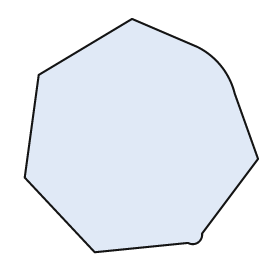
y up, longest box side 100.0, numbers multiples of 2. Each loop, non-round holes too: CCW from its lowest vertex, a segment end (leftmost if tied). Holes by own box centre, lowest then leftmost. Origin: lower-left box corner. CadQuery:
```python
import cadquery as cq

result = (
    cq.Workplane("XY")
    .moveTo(30.0, 0.0)
    .lineTo(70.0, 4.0)
    .threePointArc((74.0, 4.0), (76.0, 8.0))
    .lineTo(100.0, 40.0)
    .lineTo(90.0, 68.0)
    .threePointArc((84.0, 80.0), (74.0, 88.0))
    .lineTo(46.0, 100.0)
    .lineTo(6.0, 76.0)
    .lineTo(0.0, 32.0)
    .close()
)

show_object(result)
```